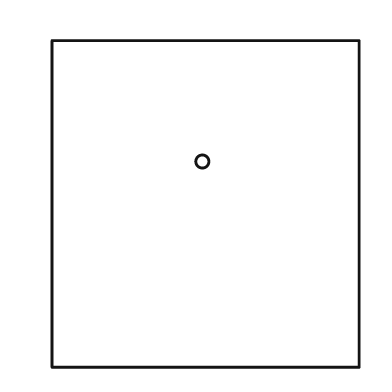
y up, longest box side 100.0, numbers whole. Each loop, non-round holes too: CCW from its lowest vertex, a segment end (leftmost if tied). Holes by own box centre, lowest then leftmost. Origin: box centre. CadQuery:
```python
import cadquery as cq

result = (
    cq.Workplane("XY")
    .moveTo(-47.0, -50.0)
    .lineTo(47.0, -50.0)
    .lineTo(47.0, 50.0)
    .lineTo(-47.0, 50.0)
    .close()
    .moveTo(-1.0, 13.0)
    .circle(2.0)
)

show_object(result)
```